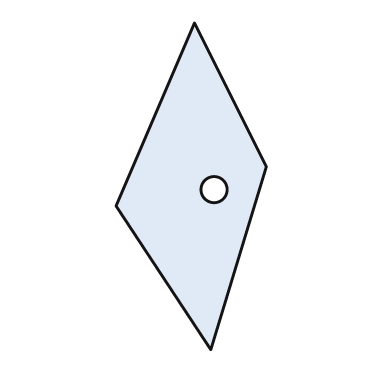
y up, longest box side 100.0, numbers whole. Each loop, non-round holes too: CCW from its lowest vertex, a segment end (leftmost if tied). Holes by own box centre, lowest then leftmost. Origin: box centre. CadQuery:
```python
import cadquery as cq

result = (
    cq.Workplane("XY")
    .moveTo(6.0, -50.0)
    .lineTo(23.0, 6.0)
    .lineTo(1.0, 50.0)
    .lineTo(-23.0, -6.0)
    .close()
    .moveTo(7.0, -1.0)
    .circle(4.0)
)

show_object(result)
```